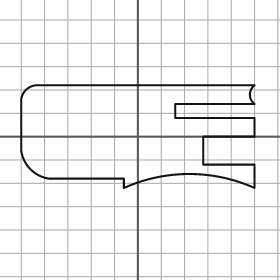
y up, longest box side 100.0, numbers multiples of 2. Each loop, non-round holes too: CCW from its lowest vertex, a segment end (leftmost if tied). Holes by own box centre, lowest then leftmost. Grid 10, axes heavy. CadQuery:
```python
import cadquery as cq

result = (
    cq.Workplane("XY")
    .moveTo(-6.0, -22.0)
    .threePointArc((22.0, -16.0), (50.0, -22.0))
    .lineTo(50.0, -12.0)
    .lineTo(28.0, -12.0)
    .lineTo(28.0, 0.0)
    .lineTo(50.0, 0.0)
    .lineTo(50.0, 8.0)
    .lineTo(16.0, 8.0)
    .lineTo(16.0, 14.0)
    .lineTo(50.0, 14.0)
    .threePointArc((48.0, 18.0), (50.0, 22.0))
    .lineTo(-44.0, 22.0)
    .threePointArc((-48.0, 20.0), (-50.0, 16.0))
    .lineTo(-50.0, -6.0)
    .threePointArc((-46.0, -14.0), (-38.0, -18.0))
    .lineTo(-6.0, -18.0)
    .close()
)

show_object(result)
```